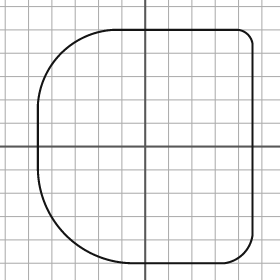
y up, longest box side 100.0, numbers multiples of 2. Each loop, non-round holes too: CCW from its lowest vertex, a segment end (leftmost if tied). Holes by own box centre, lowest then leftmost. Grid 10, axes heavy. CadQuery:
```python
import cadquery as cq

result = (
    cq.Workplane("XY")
    .moveTo(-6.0, -50.0)
    .lineTo(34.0, -50.0)
    .threePointArc((42.0, -46.0), (46.0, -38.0))
    .lineTo(46.0, 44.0)
    .threePointArc((44.0, 48.0), (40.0, 50.0))
    .lineTo(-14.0, 50.0)
    .threePointArc((-36.0, 40.0), (-46.0, 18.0))
    .lineTo(-46.0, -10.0)
    .threePointArc((-34.0, -38.0), (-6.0, -50.0))
    .close()
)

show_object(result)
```